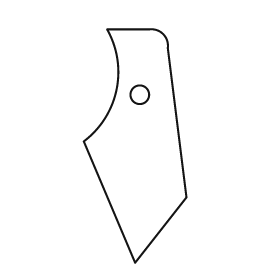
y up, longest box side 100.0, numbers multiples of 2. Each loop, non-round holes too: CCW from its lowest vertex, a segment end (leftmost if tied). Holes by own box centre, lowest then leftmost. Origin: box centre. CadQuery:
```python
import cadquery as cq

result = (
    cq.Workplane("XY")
    .moveTo(0.0, -50.0)
    .lineTo(22.0, -22.0)
    .lineTo(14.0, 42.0)
    .threePointArc((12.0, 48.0), (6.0, 50.0))
    .lineTo(-12.0, 50.0)
    .threePointArc((-8.0, 24.0), (-22.0, 2.0))
    .close()
    .moveTo(2.0, 22.0)
    .circle(4.0)
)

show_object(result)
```